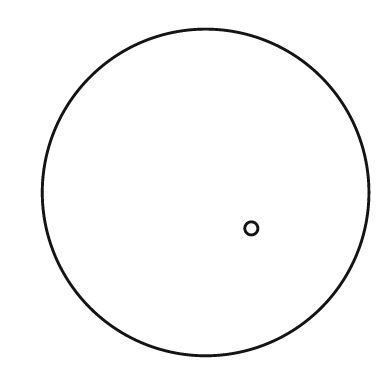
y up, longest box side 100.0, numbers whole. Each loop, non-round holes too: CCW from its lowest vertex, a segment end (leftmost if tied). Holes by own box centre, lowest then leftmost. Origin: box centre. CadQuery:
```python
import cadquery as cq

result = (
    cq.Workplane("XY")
    .moveTo(0.0, 0.0)
    .circle(50.0)
    .moveTo(14.0, -11.0)
    .circle(2.0)
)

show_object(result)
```